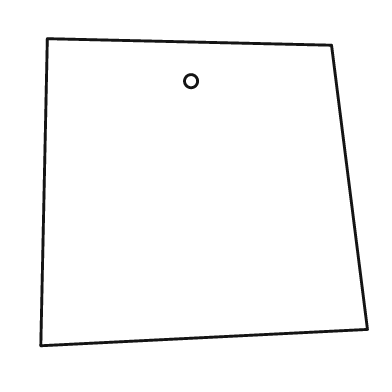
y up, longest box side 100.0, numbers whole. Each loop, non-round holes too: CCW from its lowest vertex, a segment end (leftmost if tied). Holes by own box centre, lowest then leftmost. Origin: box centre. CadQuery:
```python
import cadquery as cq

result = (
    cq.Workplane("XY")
    .moveTo(-50.0, -47.0)
    .lineTo(50.0, -42.0)
    .lineTo(39.0, 45.0)
    .lineTo(-48.0, 47.0)
    .close()
    .moveTo(-4.0, 34.0)
    .circle(2.0)
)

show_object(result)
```